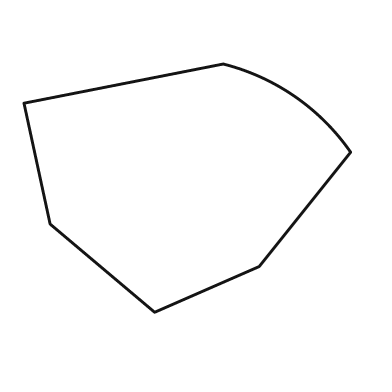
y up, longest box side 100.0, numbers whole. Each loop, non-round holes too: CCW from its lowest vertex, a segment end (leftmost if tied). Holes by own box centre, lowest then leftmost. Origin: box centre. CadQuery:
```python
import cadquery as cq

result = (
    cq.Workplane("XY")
    .moveTo(-10.0, -38.0)
    .lineTo(22.0, -24.0)
    .lineTo(50.0, 11.0)
    .threePointArc((33.0, 28.0), (11.0, 38.0))
    .lineTo(-50.0, 26.0)
    .lineTo(-42.0, -11.0)
    .close()
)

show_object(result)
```